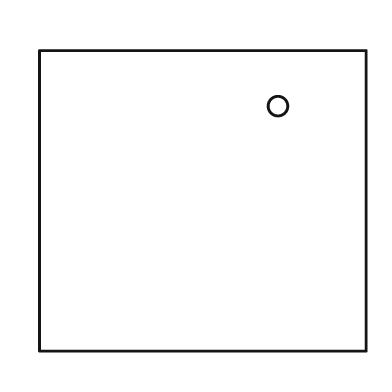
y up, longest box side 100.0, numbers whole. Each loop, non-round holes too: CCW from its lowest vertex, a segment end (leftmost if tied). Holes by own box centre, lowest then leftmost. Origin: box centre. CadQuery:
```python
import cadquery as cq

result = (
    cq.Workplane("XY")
    .moveTo(-50.0, -46.0)
    .lineTo(50.0, -46.0)
    .lineTo(50.0, 46.0)
    .lineTo(-50.0, 46.0)
    .close()
    .moveTo(23.0, 29.0)
    .circle(3.0)
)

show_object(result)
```